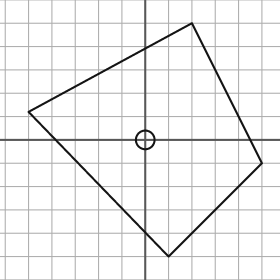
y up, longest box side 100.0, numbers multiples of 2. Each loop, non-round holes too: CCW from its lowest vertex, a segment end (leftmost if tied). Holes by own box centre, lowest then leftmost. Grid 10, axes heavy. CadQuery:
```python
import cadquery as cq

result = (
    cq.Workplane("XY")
    .moveTo(10.0, -50.0)
    .lineTo(50.0, -10.0)
    .lineTo(20.0, 50.0)
    .lineTo(-50.0, 12.0)
    .close()
    .moveTo(0.0, 0.0)
    .circle(4.0)
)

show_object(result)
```